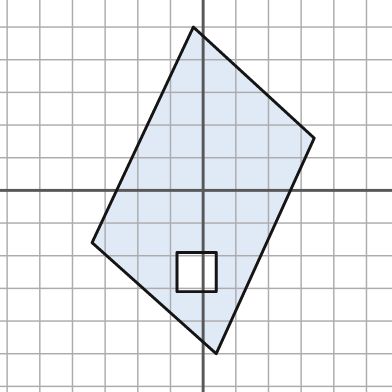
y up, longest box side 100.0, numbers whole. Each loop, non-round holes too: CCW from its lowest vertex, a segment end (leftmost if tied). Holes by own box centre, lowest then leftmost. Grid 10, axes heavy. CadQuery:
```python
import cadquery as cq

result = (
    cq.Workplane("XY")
    .moveTo(4.0, -50.0)
    .lineTo(34.0, 16.0)
    .lineTo(-3.0, 50.0)
    .lineTo(-34.0, -16.0)
    .close()
    .moveTo(-8.0, -31.0)
    .lineTo(4.0, -31.0)
    .lineTo(4.0, -19.0)
    .lineTo(-8.0, -19.0)
    .close()
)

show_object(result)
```